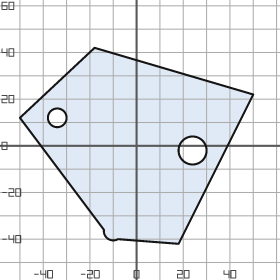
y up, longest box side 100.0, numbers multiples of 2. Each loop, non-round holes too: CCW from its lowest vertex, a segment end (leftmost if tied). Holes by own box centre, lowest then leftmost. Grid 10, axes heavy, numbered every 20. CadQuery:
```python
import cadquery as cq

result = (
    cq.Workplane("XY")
    .moveTo(18.0, -42.0)
    .lineTo(50.0, 22.0)
    .lineTo(-18.0, 42.0)
    .lineTo(-50.0, 12.0)
    .lineTo(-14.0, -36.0)
    .threePointArc((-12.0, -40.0), (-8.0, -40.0))
    .close()
    .moveTo(24.0, -2.0)
    .circle(6.0)
    .moveTo(-34.0, 12.0)
    .circle(4.0)
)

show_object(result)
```